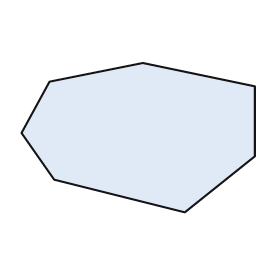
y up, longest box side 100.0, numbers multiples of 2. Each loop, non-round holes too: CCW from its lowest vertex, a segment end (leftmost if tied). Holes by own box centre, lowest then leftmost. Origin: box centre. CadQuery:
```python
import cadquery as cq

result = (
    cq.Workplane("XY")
    .moveTo(20.0, -32.0)
    .lineTo(50.0, -8.0)
    .lineTo(50.0, 22.0)
    .lineTo(2.0, 32.0)
    .lineTo(-38.0, 24.0)
    .lineTo(-50.0, 2.0)
    .lineTo(-36.0, -18.0)
    .close()
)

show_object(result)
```